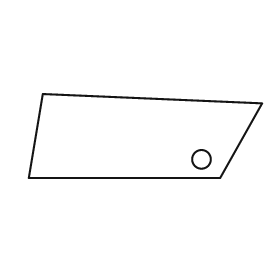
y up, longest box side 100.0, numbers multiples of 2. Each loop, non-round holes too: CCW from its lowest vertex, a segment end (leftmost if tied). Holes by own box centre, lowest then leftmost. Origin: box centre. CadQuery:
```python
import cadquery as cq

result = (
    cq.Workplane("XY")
    .moveTo(-50.0, -18.0)
    .lineTo(32.0, -18.0)
    .lineTo(50.0, 14.0)
    .lineTo(-44.0, 18.0)
    .close()
    .moveTo(24.0, -10.0)
    .circle(4.0)
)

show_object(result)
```